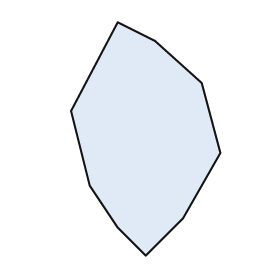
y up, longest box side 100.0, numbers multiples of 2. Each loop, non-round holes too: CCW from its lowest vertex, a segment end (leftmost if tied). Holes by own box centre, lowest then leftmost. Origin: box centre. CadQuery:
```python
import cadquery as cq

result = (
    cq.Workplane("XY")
    .moveTo(0.0, -50.0)
    .lineTo(16.0, -34.0)
    .lineTo(32.0, -6.0)
    .lineTo(24.0, 24.0)
    .lineTo(4.0, 42.0)
    .lineTo(-12.0, 50.0)
    .lineTo(-32.0, 12.0)
    .lineTo(-24.0, -20.0)
    .lineTo(-12.0, -38.0)
    .close()
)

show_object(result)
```